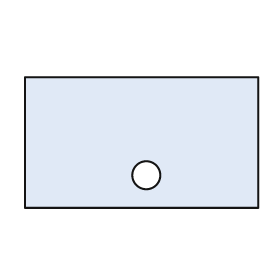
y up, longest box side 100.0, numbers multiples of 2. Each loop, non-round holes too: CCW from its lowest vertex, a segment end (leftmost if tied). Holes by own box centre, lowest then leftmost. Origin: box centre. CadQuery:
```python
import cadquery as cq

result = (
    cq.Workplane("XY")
    .moveTo(-50.0, -28.0)
    .lineTo(50.0, -28.0)
    .lineTo(50.0, 28.0)
    .lineTo(-50.0, 28.0)
    .close()
    .moveTo(2.0, -14.0)
    .circle(6.0)
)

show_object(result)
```